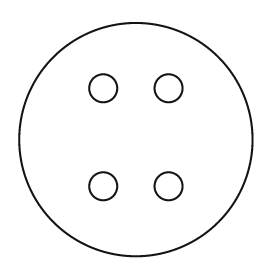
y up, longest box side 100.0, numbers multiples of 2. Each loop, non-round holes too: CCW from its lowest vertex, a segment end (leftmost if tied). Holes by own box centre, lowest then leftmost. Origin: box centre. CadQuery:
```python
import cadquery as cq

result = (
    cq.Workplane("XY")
    .moveTo(0.0, 0.0)
    .circle(50.0)
    .moveTo(-14.0, -20.0)
    .circle(6.0)
    .moveTo(14.0, -20.0)
    .circle(6.0)
    .moveTo(-14.0, 22.0)
    .circle(6.0)
    .moveTo(14.0, 22.0)
    .circle(6.0)
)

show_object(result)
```